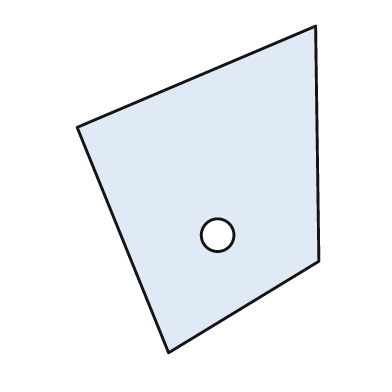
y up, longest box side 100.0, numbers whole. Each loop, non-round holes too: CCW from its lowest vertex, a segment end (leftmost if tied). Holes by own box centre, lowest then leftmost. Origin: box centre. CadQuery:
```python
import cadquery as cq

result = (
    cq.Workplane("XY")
    .moveTo(-9.0, -50.0)
    .lineTo(37.0, -22.0)
    .lineTo(36.0, 50.0)
    .lineTo(-37.0, 19.0)
    .close()
    .moveTo(6.0, -14.0)
    .circle(5.0)
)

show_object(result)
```